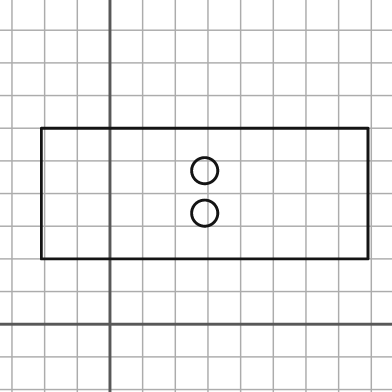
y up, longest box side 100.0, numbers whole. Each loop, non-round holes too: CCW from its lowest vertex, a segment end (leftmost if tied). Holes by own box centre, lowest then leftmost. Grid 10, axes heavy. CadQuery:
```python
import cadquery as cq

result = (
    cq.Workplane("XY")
    .moveTo(-21.0, 20.0)
    .lineTo(79.0, 20.0)
    .lineTo(79.0, 60.0)
    .lineTo(-21.0, 60.0)
    .close()
    .moveTo(29.0, 34.0)
    .circle(4.0)
    .moveTo(29.0, 47.0)
    .circle(4.0)
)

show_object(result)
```